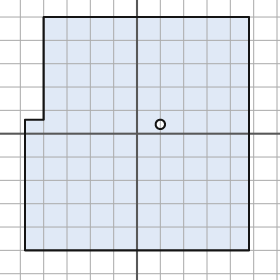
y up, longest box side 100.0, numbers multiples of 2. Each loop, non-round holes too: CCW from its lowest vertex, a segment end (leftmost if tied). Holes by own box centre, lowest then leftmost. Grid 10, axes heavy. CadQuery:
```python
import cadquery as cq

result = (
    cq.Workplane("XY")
    .moveTo(-48.0, -50.0)
    .lineTo(48.0, -50.0)
    .lineTo(48.0, 50.0)
    .lineTo(-40.0, 50.0)
    .lineTo(-40.0, 6.0)
    .lineTo(-48.0, 6.0)
    .close()
    .moveTo(10.0, 4.0)
    .circle(2.0)
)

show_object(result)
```